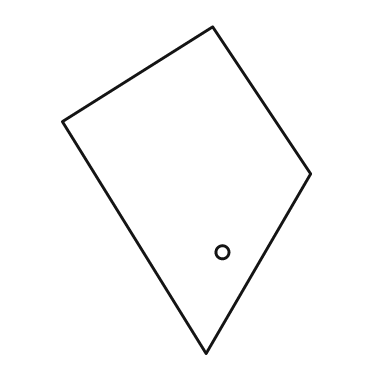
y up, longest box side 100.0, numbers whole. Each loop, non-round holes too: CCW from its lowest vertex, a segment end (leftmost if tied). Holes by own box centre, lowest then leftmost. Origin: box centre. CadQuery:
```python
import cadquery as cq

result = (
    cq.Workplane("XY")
    .moveTo(6.0, -50.0)
    .lineTo(38.0, 5.0)
    .lineTo(8.0, 50.0)
    .lineTo(-38.0, 21.0)
    .close()
    .moveTo(11.0, -19.0)
    .circle(2.0)
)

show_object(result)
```